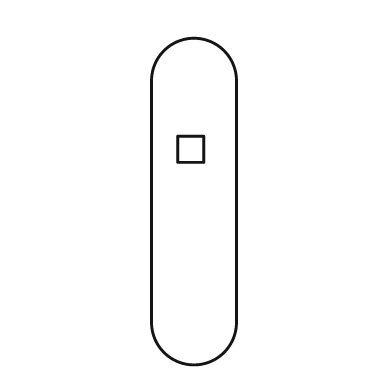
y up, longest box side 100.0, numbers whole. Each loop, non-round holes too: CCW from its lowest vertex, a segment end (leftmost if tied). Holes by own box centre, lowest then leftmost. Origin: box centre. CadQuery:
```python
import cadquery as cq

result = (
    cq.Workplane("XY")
    .moveTo(-13.0, -37.0)
    .threePointArc((0.0, -50.0), (13.0, -37.0))
    .lineTo(13.0, 37.0)
    .threePointArc((0.0, 50.0), (-13.0, 37.0))
    .close()
    .moveTo(-5.0, 12.0)
    .lineTo(3.0, 12.0)
    .lineTo(3.0, 20.0)
    .lineTo(-5.0, 20.0)
    .close()
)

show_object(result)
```